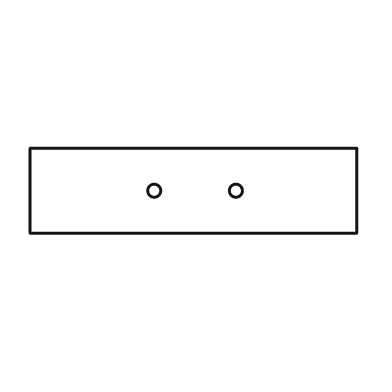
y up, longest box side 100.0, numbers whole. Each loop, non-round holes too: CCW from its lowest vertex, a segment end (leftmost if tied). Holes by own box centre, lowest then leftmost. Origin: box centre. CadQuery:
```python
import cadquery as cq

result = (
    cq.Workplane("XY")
    .moveTo(-50.0, -13.0)
    .lineTo(50.0, -13.0)
    .lineTo(50.0, 13.0)
    .lineTo(-50.0, 13.0)
    .close()
    .moveTo(-12.0, 0.0)
    .circle(2.0)
    .moveTo(13.0, 0.0)
    .circle(2.0)
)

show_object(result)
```